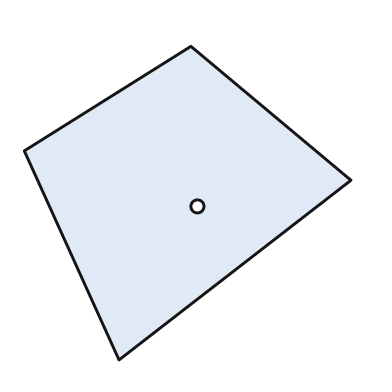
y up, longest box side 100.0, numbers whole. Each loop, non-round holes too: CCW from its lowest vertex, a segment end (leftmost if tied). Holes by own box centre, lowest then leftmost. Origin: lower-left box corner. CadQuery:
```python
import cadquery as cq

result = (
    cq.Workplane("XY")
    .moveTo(29.0, 0.0)
    .lineTo(100.0, 55.0)
    .lineTo(51.0, 96.0)
    .lineTo(0.0, 64.0)
    .close()
    .moveTo(53.0, 47.0)
    .circle(2.0)
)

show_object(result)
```